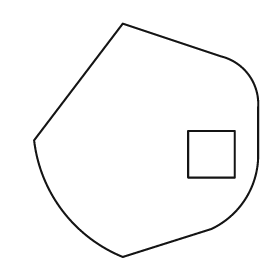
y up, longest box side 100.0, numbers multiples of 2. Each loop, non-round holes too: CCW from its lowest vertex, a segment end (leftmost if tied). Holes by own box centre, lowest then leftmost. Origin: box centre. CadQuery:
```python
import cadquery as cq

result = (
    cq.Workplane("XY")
    .moveTo(-10.0, -50.0)
    .lineTo(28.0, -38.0)
    .threePointArc((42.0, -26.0), (48.0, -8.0))
    .lineTo(48.0, 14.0)
    .threePointArc((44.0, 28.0), (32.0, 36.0))
    .lineTo(-10.0, 50.0)
    .lineTo(-48.0, 0.0)
    .threePointArc((-36.0, -30.0), (-10.0, -50.0))
    .close()
    .moveTo(18.0, -16.0)
    .lineTo(38.0, -16.0)
    .lineTo(38.0, 4.0)
    .lineTo(18.0, 4.0)
    .close()
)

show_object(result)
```